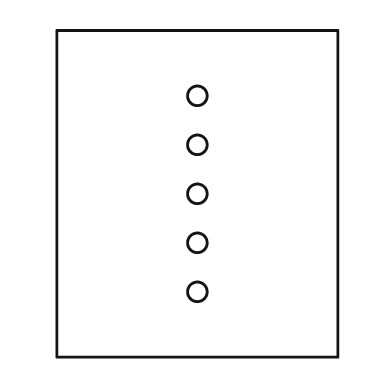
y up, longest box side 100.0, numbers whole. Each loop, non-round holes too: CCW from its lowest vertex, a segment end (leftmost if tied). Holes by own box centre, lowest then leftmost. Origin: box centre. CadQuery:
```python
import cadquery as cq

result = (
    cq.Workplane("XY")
    .moveTo(-43.0, -50.0)
    .lineTo(43.0, -50.0)
    .lineTo(43.0, 50.0)
    .lineTo(-43.0, 50.0)
    .close()
    .moveTo(0.0, -30.0)
    .circle(3.0)
    .moveTo(0.0, -15.0)
    .circle(3.0)
    .moveTo(0.0, 0.0)
    .circle(3.0)
    .moveTo(0.0, 15.0)
    .circle(3.0)
    .moveTo(0.0, 30.0)
    .circle(3.0)
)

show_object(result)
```